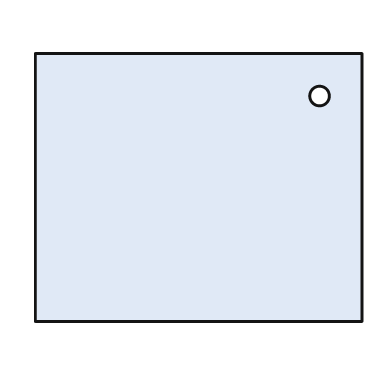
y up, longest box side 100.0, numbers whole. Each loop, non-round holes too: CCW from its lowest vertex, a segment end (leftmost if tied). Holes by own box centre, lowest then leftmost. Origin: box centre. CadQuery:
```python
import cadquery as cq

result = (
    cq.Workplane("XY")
    .moveTo(-50.0, -41.0)
    .lineTo(50.0, -41.0)
    .lineTo(50.0, 41.0)
    .lineTo(-50.0, 41.0)
    .close()
    .moveTo(37.0, 28.0)
    .circle(3.0)
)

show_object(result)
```